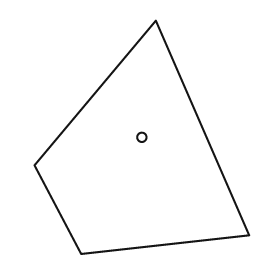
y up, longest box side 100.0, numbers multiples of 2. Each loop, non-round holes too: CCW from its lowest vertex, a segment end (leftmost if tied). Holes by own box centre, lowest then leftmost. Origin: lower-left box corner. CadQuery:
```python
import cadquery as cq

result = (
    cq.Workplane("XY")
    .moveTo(20.0, 0.0)
    .lineTo(92.0, 8.0)
    .lineTo(52.0, 100.0)
    .lineTo(0.0, 38.0)
    .close()
    .moveTo(46.0, 50.0)
    .circle(2.0)
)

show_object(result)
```